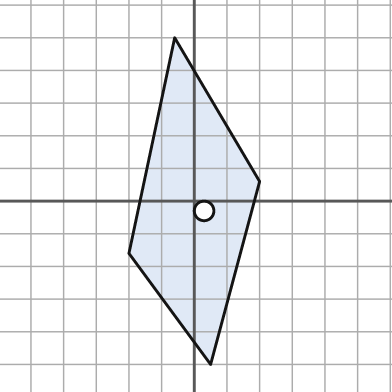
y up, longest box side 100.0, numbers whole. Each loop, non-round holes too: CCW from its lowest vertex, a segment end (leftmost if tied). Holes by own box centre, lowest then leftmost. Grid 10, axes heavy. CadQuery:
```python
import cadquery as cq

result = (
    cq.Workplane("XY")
    .moveTo(5.0, -50.0)
    .lineTo(20.0, 6.0)
    .lineTo(-6.0, 50.0)
    .lineTo(-20.0, -16.0)
    .close()
    .moveTo(3.0, -3.0)
    .circle(3.0)
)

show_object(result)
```